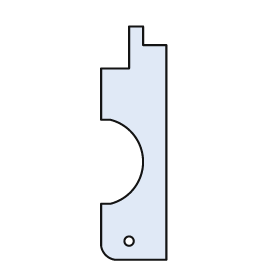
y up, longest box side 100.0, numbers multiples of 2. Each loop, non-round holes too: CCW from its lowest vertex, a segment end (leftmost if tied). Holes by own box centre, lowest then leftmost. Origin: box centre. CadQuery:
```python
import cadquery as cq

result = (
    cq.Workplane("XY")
    .moveTo(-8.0, -50.0)
    .lineTo(14.0, -50.0)
    .lineTo(14.0, 42.0)
    .lineTo(4.0, 42.0)
    .lineTo(4.0, 50.0)
    .lineTo(-2.0, 50.0)
    .lineTo(-2.0, 32.0)
    .lineTo(-14.0, 32.0)
    .lineTo(-14.0, 10.0)
    .lineTo(-10.0, 10.0)
    .threePointArc((4.0, -8.0), (-10.0, -26.0))
    .lineTo(-14.0, -26.0)
    .lineTo(-14.0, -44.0)
    .threePointArc((-12.0, -48.0), (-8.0, -50.0))
    .close()
    .moveTo(-2.0, -42.0)
    .circle(2.0)
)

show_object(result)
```